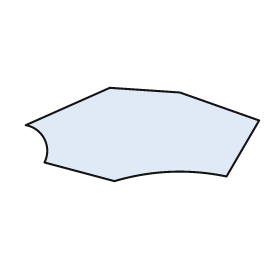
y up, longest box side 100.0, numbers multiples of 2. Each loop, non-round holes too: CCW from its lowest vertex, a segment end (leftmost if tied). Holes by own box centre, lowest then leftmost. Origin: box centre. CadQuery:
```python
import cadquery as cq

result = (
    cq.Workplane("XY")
    .moveTo(-12.0, -20.0)
    .threePointArc((12.0, -16.0), (36.0, -18.0))
    .lineTo(50.0, 6.0)
    .lineTo(16.0, 18.0)
    .lineTo(-14.0, 20.0)
    .lineTo(-50.0, 4.0)
    .threePointArc((-42.0, -2.0), (-42.0, -12.0))
    .close()
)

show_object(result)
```